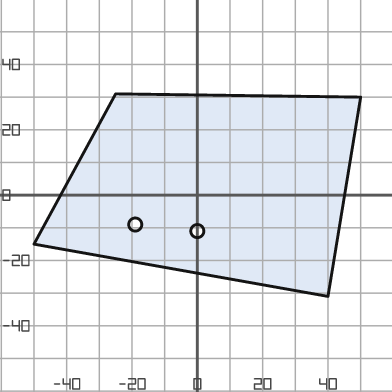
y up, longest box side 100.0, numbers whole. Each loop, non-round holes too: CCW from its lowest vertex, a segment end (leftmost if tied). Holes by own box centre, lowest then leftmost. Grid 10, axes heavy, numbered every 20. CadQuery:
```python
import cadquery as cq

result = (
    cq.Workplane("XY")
    .moveTo(40.0, -31.0)
    .lineTo(50.0, 30.0)
    .lineTo(-25.0, 31.0)
    .lineTo(-50.0, -15.0)
    .close()
    .moveTo(0.0, -11.0)
    .circle(2.0)
    .moveTo(-19.0, -9.0)
    .circle(2.0)
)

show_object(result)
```